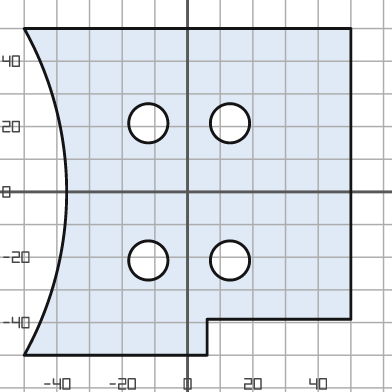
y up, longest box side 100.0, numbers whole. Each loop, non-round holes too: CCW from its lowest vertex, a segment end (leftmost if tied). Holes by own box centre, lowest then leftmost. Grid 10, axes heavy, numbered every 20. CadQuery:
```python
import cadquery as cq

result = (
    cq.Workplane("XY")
    .moveTo(-50.0, -50.0)
    .lineTo(6.0, -50.0)
    .lineTo(6.0, -39.0)
    .lineTo(50.0, -39.0)
    .lineTo(50.0, 50.0)
    .lineTo(-50.0, 50.0)
    .threePointArc((-37.0, 0.0), (-50.0, -50.0))
    .close()
    .moveTo(-12.0, -21.0)
    .circle(6.0)
    .moveTo(13.0, -21.0)
    .circle(6.0)
    .moveTo(-12.0, 21.0)
    .circle(6.0)
    .moveTo(13.0, 21.0)
    .circle(6.0)
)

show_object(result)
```